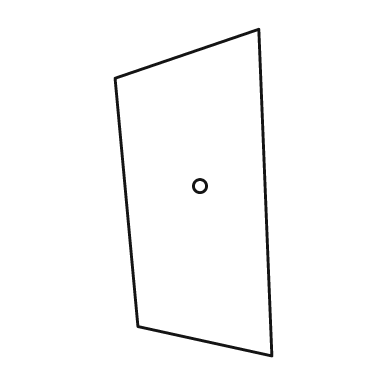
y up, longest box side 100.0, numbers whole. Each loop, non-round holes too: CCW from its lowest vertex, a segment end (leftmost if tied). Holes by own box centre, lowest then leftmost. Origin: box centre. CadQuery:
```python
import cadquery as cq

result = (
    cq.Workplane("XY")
    .moveTo(24.0, -50.0)
    .lineTo(20.0, 50.0)
    .lineTo(-24.0, 35.0)
    .lineTo(-17.0, -41.0)
    .close()
    .moveTo(2.0, 2.0)
    .circle(2.0)
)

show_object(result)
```